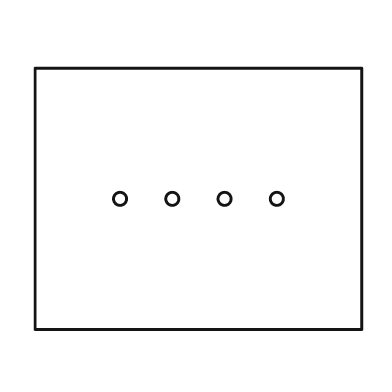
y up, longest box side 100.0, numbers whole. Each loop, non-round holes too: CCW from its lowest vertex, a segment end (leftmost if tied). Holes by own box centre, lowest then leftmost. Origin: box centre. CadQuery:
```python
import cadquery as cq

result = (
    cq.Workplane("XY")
    .moveTo(-50.0, -40.0)
    .lineTo(50.0, -40.0)
    .lineTo(50.0, 40.0)
    .lineTo(-50.0, 40.0)
    .close()
    .moveTo(-24.0, 0.0)
    .circle(2.0)
    .moveTo(-8.0, 0.0)
    .circle(2.0)
    .moveTo(8.0, 0.0)
    .circle(2.0)
    .moveTo(24.0, 0.0)
    .circle(2.0)
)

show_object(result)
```